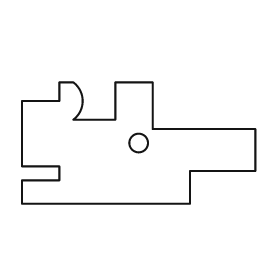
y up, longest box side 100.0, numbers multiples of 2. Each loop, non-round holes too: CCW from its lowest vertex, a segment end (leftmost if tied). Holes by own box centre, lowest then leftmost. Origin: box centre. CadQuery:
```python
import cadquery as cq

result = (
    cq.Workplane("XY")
    .moveTo(-50.0, -26.0)
    .lineTo(22.0, -26.0)
    .lineTo(22.0, -12.0)
    .lineTo(50.0, -12.0)
    .lineTo(50.0, 6.0)
    .lineTo(6.0, 6.0)
    .lineTo(6.0, 26.0)
    .lineTo(-10.0, 26.0)
    .lineTo(-10.0, 10.0)
    .lineTo(-28.0, 10.0)
    .threePointArc((-24.0, 18.0), (-28.0, 26.0))
    .lineTo(-34.0, 26.0)
    .lineTo(-34.0, 18.0)
    .lineTo(-50.0, 18.0)
    .lineTo(-50.0, -10.0)
    .lineTo(-34.0, -10.0)
    .lineTo(-34.0, -16.0)
    .lineTo(-50.0, -16.0)
    .close()
    .moveTo(0.0, 0.0)
    .circle(4.0)
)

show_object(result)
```